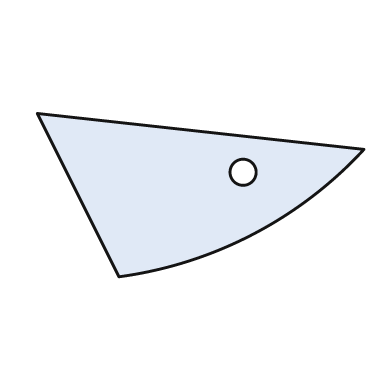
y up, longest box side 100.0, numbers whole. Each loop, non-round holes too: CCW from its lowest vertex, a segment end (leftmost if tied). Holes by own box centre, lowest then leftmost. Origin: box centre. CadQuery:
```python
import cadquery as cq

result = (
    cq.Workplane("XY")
    .moveTo(-25.0, -25.0)
    .threePointArc((16.0, -12.0), (50.0, 14.0))
    .lineTo(-50.0, 25.0)
    .close()
    .moveTo(13.0, 7.0)
    .circle(4.0)
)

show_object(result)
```